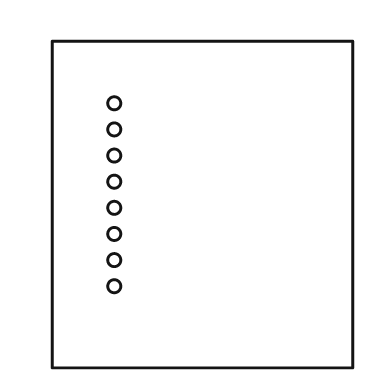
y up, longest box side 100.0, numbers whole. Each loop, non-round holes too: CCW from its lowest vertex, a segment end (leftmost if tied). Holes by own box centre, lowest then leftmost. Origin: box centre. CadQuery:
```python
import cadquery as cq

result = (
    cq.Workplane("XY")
    .moveTo(-46.0, -50.0)
    .lineTo(46.0, -50.0)
    .lineTo(46.0, 50.0)
    .lineTo(-46.0, 50.0)
    .close()
    .moveTo(-27.0, -25.0)
    .circle(2.0)
    .moveTo(-27.0, -17.0)
    .circle(2.0)
    .moveTo(-27.0, -9.0)
    .circle(2.0)
    .moveTo(-27.0, -1.0)
    .circle(2.0)
    .moveTo(-27.0, 7.0)
    .circle(2.0)
    .moveTo(-27.0, 15.0)
    .circle(2.0)
    .moveTo(-27.0, 23.0)
    .circle(2.0)
    .moveTo(-27.0, 31.0)
    .circle(2.0)
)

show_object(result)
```